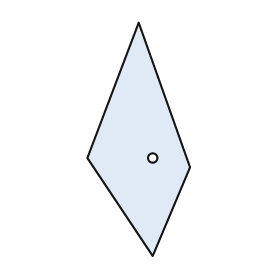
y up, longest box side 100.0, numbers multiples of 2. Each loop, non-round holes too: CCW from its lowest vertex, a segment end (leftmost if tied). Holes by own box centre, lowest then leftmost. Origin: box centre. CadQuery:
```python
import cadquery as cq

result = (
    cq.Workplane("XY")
    .moveTo(6.0, -50.0)
    .lineTo(22.0, -12.0)
    .lineTo(0.0, 50.0)
    .lineTo(-22.0, -8.0)
    .close()
    .moveTo(6.0, -8.0)
    .circle(2.0)
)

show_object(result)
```